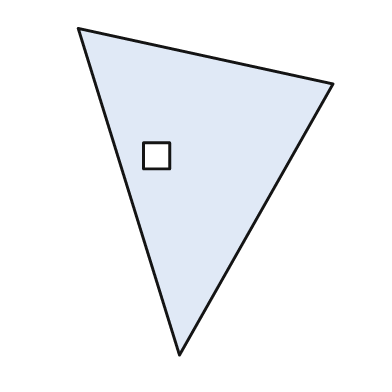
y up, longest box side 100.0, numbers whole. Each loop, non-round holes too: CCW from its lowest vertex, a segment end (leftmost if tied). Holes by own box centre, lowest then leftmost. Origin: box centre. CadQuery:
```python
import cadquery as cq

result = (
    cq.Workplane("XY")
    .moveTo(-8.0, -50.0)
    .lineTo(39.0, 33.0)
    .lineTo(-39.0, 50.0)
    .close()
    .moveTo(-19.0, 7.0)
    .lineTo(-11.0, 7.0)
    .lineTo(-11.0, 15.0)
    .lineTo(-19.0, 15.0)
    .close()
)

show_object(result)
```